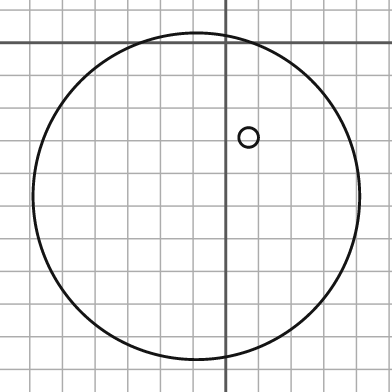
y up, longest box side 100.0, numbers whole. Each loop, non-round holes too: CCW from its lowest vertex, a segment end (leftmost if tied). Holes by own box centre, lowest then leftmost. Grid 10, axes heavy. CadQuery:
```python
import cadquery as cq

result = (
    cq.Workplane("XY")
    .moveTo(-9.0, -47.0)
    .circle(50.0)
    .moveTo(7.0, -29.0)
    .circle(3.0)
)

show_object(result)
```